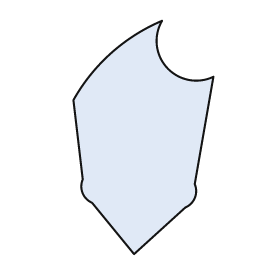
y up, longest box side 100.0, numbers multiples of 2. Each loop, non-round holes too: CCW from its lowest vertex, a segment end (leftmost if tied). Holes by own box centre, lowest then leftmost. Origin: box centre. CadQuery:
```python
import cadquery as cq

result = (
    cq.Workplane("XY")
    .moveTo(-4.0, -50.0)
    .lineTo(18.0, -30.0)
    .threePointArc((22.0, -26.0), (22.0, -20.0))
    .lineTo(30.0, 26.0)
    .threePointArc((10.0, 30.0), (8.0, 50.0))
    .threePointArc((-14.0, 36.0), (-30.0, 16.0))
    .lineTo(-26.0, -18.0)
    .threePointArc((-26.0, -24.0), (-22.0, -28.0))
    .close()
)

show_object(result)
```